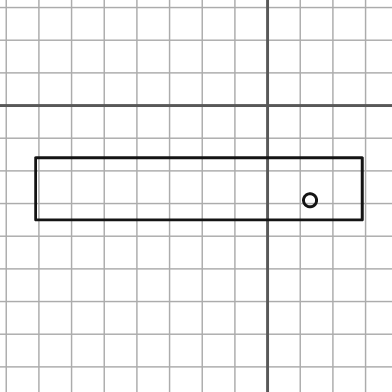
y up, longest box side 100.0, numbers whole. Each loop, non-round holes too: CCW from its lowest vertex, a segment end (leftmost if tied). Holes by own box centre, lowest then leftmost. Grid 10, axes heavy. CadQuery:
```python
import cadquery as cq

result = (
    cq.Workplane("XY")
    .moveTo(-71.0, -35.0)
    .lineTo(29.0, -35.0)
    .lineTo(29.0, -16.0)
    .lineTo(-71.0, -16.0)
    .close()
    .moveTo(13.0, -29.0)
    .circle(2.0)
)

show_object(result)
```